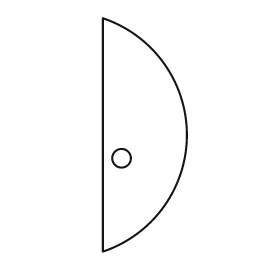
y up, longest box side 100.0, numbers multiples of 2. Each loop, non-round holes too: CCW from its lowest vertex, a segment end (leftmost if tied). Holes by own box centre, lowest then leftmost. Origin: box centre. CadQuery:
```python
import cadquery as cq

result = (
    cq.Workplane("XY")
    .moveTo(-18.0, -50.0)
    .threePointArc((18.0, 0.0), (-18.0, 50.0))
    .close()
    .moveTo(-10.0, -10.0)
    .circle(4.0)
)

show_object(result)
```